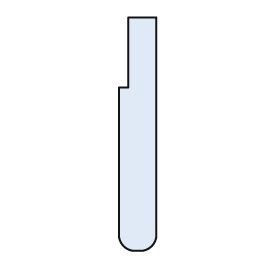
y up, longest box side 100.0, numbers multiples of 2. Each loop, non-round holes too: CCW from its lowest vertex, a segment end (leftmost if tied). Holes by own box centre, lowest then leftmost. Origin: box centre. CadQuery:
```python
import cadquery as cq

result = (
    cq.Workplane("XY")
    .moveTo(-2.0, -50.0)
    .lineTo(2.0, -50.0)
    .threePointArc((6.0, -48.0), (8.0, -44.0))
    .lineTo(8.0, 50.0)
    .lineTo(-4.0, 50.0)
    .lineTo(-4.0, 20.0)
    .lineTo(-8.0, 20.0)
    .lineTo(-8.0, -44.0)
    .threePointArc((-6.0, -48.0), (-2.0, -50.0))
    .close()
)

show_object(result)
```